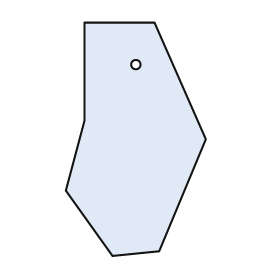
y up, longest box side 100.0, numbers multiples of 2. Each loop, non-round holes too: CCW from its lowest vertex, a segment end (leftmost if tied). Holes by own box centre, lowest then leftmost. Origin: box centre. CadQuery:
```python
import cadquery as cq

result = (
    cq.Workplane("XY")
    .moveTo(-10.0, -50.0)
    .lineTo(10.0, -48.0)
    .lineTo(30.0, 0.0)
    .lineTo(8.0, 50.0)
    .lineTo(-22.0, 50.0)
    .lineTo(-22.0, 8.0)
    .lineTo(-30.0, -22.0)
    .close()
    .moveTo(0.0, 32.0)
    .circle(2.0)
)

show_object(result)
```